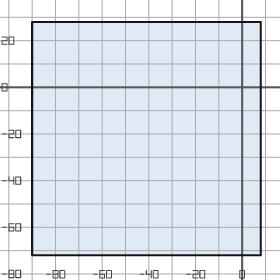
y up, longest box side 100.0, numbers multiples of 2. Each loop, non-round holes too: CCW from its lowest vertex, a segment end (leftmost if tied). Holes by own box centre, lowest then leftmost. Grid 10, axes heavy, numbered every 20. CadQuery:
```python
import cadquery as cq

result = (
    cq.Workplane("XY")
    .moveTo(-90.0, -72.0)
    .lineTo(8.0, -72.0)
    .lineTo(8.0, 28.0)
    .lineTo(-90.0, 28.0)
    .close()
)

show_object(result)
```